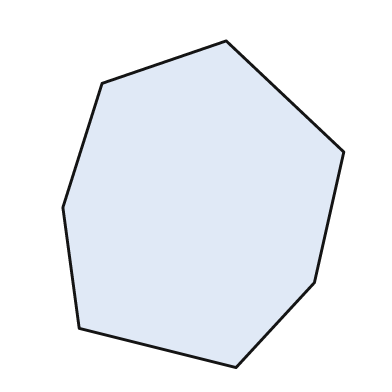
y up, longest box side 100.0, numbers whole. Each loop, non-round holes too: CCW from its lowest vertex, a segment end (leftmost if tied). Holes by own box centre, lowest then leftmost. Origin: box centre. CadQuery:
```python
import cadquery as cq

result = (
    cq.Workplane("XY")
    .moveTo(10.0, -50.0)
    .lineTo(34.0, -24.0)
    .lineTo(43.0, 16.0)
    .lineTo(7.0, 50.0)
    .lineTo(-31.0, 37.0)
    .lineTo(-43.0, -1.0)
    .lineTo(-38.0, -38.0)
    .close()
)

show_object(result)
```